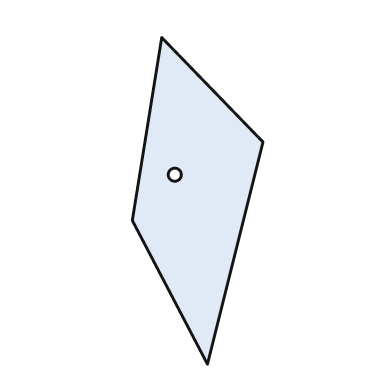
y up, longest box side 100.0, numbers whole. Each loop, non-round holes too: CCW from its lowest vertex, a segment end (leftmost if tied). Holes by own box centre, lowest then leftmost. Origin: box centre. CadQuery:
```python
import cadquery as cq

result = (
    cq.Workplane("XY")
    .moveTo(3.0, -50.0)
    .lineTo(20.0, 18.0)
    .lineTo(-11.0, 50.0)
    .lineTo(-20.0, -6.0)
    .close()
    .moveTo(-7.0, 8.0)
    .circle(2.0)
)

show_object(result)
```